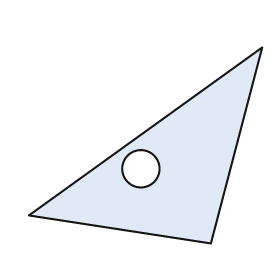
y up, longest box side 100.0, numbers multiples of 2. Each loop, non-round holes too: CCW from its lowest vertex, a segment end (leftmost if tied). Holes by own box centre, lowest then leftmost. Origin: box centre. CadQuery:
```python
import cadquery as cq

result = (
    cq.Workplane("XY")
    .moveTo(28.0, -42.0)
    .lineTo(50.0, 42.0)
    .lineTo(-50.0, -30.0)
    .close()
    .moveTo(-2.0, -10.0)
    .circle(8.0)
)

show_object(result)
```